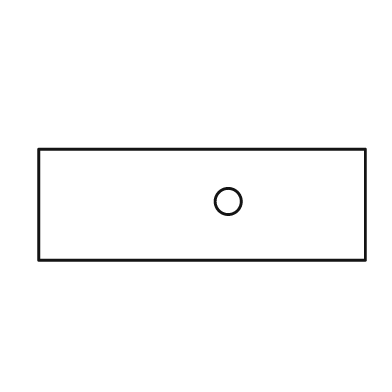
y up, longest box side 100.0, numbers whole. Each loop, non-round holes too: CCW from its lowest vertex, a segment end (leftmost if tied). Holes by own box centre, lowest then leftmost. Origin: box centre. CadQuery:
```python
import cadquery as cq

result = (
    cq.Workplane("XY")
    .moveTo(-50.0, -17.0)
    .lineTo(50.0, -17.0)
    .lineTo(50.0, 17.0)
    .lineTo(-50.0, 17.0)
    .close()
    .moveTo(8.0, 1.0)
    .circle(4.0)
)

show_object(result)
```